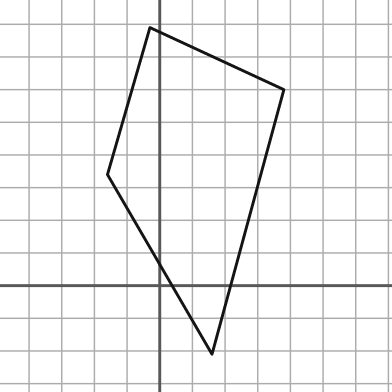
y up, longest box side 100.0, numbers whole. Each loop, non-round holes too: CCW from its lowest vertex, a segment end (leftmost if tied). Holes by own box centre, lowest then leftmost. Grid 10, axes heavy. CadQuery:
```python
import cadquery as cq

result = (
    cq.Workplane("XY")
    .moveTo(16.0, -21.0)
    .lineTo(38.0, 60.0)
    .lineTo(-3.0, 79.0)
    .lineTo(-16.0, 34.0)
    .close()
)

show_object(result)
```